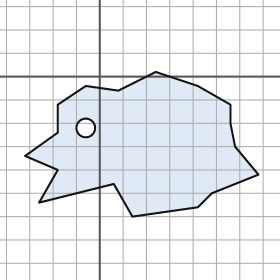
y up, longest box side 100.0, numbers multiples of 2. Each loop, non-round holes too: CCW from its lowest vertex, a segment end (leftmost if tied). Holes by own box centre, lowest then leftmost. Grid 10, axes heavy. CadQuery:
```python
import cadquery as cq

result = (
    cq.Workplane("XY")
    .moveTo(14.0, -60.0)
    .lineTo(42.0, -56.0)
    .lineTo(48.0, -50.0)
    .lineTo(68.0, -42.0)
    .lineTo(58.0, -30.0)
    .lineTo(56.0, -20.0)
    .lineTo(56.0, -12.0)
    .lineTo(42.0, -4.0)
    .lineTo(24.0, 2.0)
    .lineTo(8.0, -6.0)
    .lineTo(-6.0, -4.0)
    .lineTo(-18.0, -12.0)
    .lineTo(-18.0, -24.0)
    .lineTo(-32.0, -34.0)
    .lineTo(-18.0, -40.0)
    .lineTo(-26.0, -54.0)
    .lineTo(6.0, -46.0)
    .close()
    .moveTo(-6.0, -22.0)
    .circle(4.0)
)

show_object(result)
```